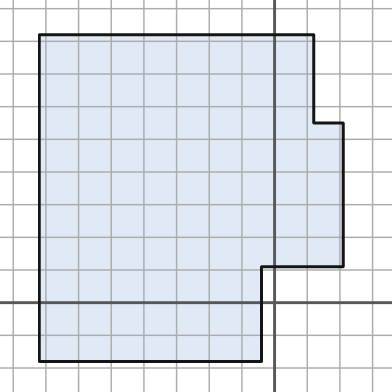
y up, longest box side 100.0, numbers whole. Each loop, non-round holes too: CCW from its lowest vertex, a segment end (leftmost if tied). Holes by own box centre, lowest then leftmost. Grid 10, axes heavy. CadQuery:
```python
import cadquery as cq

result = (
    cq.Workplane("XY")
    .moveTo(-72.0, -18.0)
    .lineTo(-4.0, -18.0)
    .lineTo(-4.0, 11.0)
    .lineTo(21.0, 11.0)
    .lineTo(21.0, 55.0)
    .lineTo(12.0, 55.0)
    .lineTo(12.0, 82.0)
    .lineTo(-72.0, 82.0)
    .close()
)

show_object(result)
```